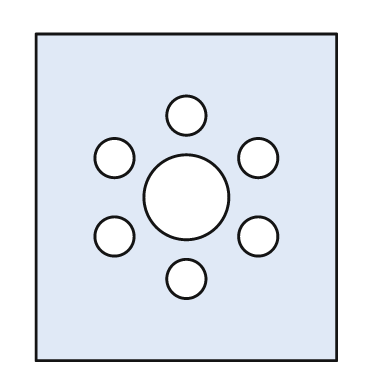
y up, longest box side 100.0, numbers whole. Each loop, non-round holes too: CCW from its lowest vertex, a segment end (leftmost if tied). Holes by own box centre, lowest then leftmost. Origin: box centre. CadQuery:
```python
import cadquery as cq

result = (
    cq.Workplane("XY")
    .moveTo(-46.0, -50.0)
    .lineTo(46.0, -50.0)
    .lineTo(46.0, 50.0)
    .lineTo(-46.0, 50.0)
    .close()
    .moveTo(0.0, -25.0)
    .circle(6.0)
    .moveTo(-22.0, -12.0)
    .circle(6.0)
    .moveTo(22.0, -12.0)
    .circle(6.0)
    .moveTo(0.0, 0.0)
    .circle(13.0)
    .moveTo(-22.0, 12.0)
    .circle(6.0)
    .moveTo(22.0, 12.0)
    .circle(6.0)
    .moveTo(0.0, 25.0)
    .circle(6.0)
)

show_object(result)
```